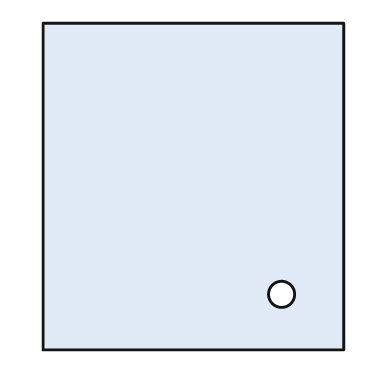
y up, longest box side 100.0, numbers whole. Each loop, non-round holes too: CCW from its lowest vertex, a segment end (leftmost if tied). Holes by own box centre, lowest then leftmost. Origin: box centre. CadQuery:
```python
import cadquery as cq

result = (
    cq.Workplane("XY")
    .moveTo(-46.0, -50.0)
    .lineTo(46.0, -50.0)
    .lineTo(46.0, 50.0)
    .lineTo(-46.0, 50.0)
    .close()
    .moveTo(27.0, -33.0)
    .circle(4.0)
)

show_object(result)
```